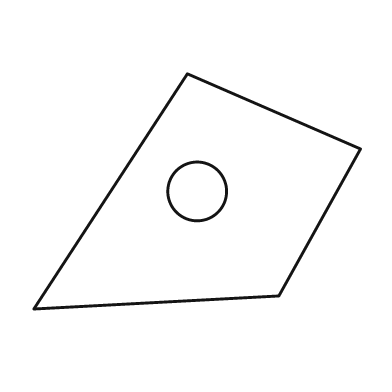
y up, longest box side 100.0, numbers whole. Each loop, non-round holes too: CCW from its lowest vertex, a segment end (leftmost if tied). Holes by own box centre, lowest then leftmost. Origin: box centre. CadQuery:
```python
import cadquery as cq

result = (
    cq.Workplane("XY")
    .moveTo(-50.0, -36.0)
    .lineTo(25.0, -32.0)
    .lineTo(50.0, 13.0)
    .lineTo(-3.0, 36.0)
    .close()
    .moveTo(0.0, 0.0)
    .circle(9.0)
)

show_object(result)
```